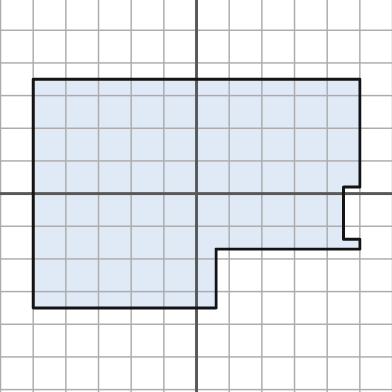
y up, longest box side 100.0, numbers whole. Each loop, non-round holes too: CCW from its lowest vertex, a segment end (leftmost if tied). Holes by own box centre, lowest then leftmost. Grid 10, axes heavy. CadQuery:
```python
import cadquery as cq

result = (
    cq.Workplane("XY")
    .moveTo(-50.0, -35.0)
    .lineTo(6.0, -35.0)
    .lineTo(6.0, -17.0)
    .lineTo(50.0, -17.0)
    .lineTo(50.0, -14.0)
    .lineTo(45.0, -14.0)
    .lineTo(45.0, 2.0)
    .lineTo(50.0, 2.0)
    .lineTo(50.0, 35.0)
    .lineTo(-50.0, 35.0)
    .close()
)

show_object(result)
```